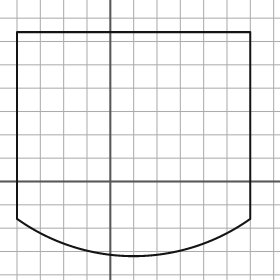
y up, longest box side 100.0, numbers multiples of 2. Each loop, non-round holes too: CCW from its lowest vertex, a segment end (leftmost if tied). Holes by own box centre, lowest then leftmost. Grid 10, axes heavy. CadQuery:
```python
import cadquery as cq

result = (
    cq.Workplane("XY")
    .moveTo(-40.0, -16.0)
    .threePointArc((10.0, -32.0), (60.0, -16.0))
    .lineTo(60.0, 64.0)
    .lineTo(-40.0, 64.0)
    .close()
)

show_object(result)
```